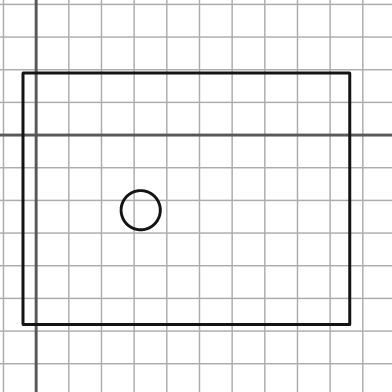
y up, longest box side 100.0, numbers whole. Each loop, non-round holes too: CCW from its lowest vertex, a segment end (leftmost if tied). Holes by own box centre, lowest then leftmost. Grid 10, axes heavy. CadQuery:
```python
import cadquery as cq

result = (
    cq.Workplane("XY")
    .moveTo(-4.0, -58.0)
    .lineTo(96.0, -58.0)
    .lineTo(96.0, 19.0)
    .lineTo(-4.0, 19.0)
    .close()
    .moveTo(32.0, -23.0)
    .circle(6.0)
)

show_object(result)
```